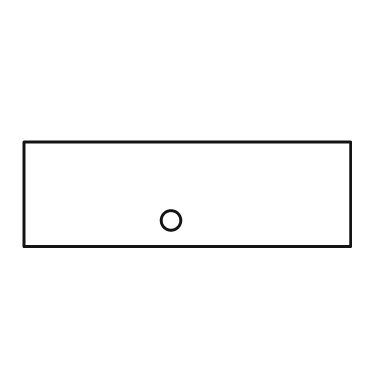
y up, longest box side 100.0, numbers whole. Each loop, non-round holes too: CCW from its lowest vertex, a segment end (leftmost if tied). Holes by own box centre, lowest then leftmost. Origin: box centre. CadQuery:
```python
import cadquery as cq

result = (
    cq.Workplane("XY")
    .moveTo(-50.0, -16.0)
    .lineTo(50.0, -16.0)
    .lineTo(50.0, 16.0)
    .lineTo(-50.0, 16.0)
    .close()
    .moveTo(-5.0, -8.0)
    .circle(3.0)
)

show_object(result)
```